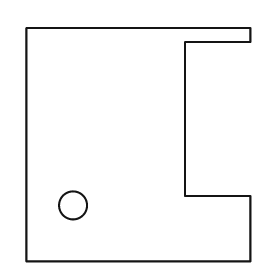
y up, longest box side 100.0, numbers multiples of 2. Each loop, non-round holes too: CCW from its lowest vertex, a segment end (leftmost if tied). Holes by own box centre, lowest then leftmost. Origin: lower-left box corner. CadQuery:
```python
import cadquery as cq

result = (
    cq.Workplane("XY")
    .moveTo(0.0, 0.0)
    .lineTo(96.0, 0.0)
    .lineTo(96.0, 28.0)
    .lineTo(68.0, 28.0)
    .lineTo(68.0, 94.0)
    .lineTo(96.0, 94.0)
    .lineTo(96.0, 100.0)
    .lineTo(0.0, 100.0)
    .close()
    .moveTo(20.0, 24.0)
    .circle(6.0)
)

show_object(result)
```